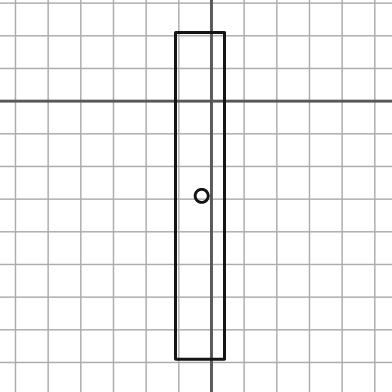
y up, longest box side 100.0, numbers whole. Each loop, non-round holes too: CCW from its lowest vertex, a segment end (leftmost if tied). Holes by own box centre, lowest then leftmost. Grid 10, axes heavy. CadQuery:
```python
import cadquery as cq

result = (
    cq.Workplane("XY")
    .moveTo(-11.0, -79.0)
    .lineTo(4.0, -79.0)
    .lineTo(4.0, 21.0)
    .lineTo(-11.0, 21.0)
    .close()
    .moveTo(-3.0, -29.0)
    .circle(2.0)
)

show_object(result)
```